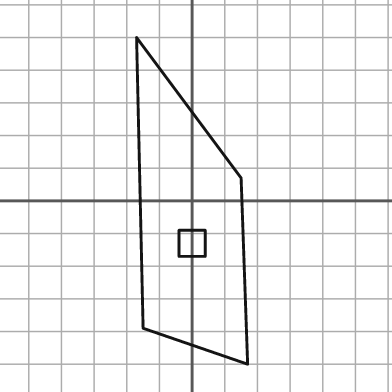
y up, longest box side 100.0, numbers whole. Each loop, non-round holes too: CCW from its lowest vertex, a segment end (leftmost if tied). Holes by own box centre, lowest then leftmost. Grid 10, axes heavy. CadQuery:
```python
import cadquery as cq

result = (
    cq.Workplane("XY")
    .moveTo(17.0, -50.0)
    .lineTo(15.0, 7.0)
    .lineTo(-17.0, 50.0)
    .lineTo(-15.0, -39.0)
    .close()
    .moveTo(-4.0, -17.0)
    .lineTo(4.0, -17.0)
    .lineTo(4.0, -9.0)
    .lineTo(-4.0, -9.0)
    .close()
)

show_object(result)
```